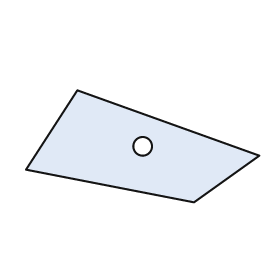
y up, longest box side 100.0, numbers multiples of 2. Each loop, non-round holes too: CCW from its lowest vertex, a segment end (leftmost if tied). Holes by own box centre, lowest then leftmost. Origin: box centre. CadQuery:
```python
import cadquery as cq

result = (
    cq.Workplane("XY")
    .moveTo(22.0, -24.0)
    .lineTo(50.0, -4.0)
    .lineTo(-28.0, 24.0)
    .lineTo(-50.0, -10.0)
    .close()
    .moveTo(0.0, 0.0)
    .circle(4.0)
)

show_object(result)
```